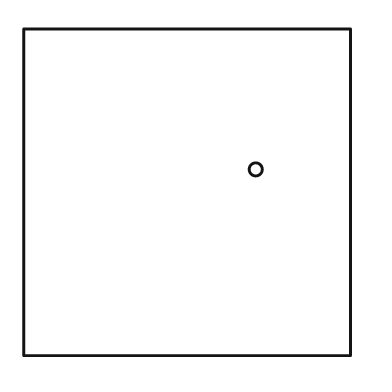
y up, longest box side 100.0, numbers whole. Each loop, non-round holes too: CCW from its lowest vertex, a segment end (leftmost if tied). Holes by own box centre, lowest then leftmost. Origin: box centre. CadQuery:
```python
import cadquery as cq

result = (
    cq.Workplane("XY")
    .moveTo(-50.0, -50.0)
    .lineTo(50.0, -50.0)
    .lineTo(50.0, 50.0)
    .lineTo(-50.0, 50.0)
    .close()
    .moveTo(21.0, 7.0)
    .circle(2.0)
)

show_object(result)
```